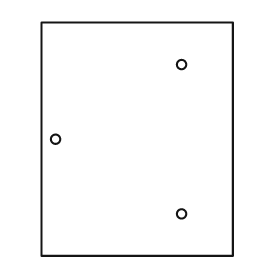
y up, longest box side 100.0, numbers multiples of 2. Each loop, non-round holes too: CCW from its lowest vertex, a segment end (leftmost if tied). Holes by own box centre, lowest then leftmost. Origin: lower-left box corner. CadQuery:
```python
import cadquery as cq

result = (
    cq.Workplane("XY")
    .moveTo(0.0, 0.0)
    .lineTo(82.0, 0.0)
    .lineTo(82.0, 100.0)
    .lineTo(0.0, 100.0)
    .close()
    .moveTo(60.0, 18.0)
    .circle(2.0)
    .moveTo(6.0, 50.0)
    .circle(2.0)
    .moveTo(60.0, 82.0)
    .circle(2.0)
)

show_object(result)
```